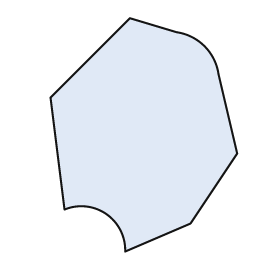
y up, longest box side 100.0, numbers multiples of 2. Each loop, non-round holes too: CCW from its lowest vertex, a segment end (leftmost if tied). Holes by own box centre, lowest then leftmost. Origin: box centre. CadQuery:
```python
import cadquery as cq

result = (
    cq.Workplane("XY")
    .moveTo(-8.0, -50.0)
    .lineTo(20.0, -38.0)
    .lineTo(40.0, -8.0)
    .lineTo(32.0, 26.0)
    .threePointArc((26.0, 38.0), (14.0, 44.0))
    .lineTo(-6.0, 50.0)
    .lineTo(-40.0, 16.0)
    .lineTo(-34.0, -32.0)
    .threePointArc((-16.0, -34.0), (-8.0, -50.0))
    .close()
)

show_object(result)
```